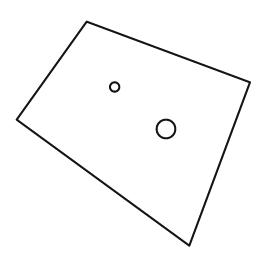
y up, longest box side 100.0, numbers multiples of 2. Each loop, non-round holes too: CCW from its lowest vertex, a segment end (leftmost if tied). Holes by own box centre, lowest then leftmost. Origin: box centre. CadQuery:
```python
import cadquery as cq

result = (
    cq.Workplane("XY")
    .moveTo(24.0, -48.0)
    .lineTo(50.0, 22.0)
    .lineTo(-20.0, 48.0)
    .lineTo(-50.0, 6.0)
    .close()
    .moveTo(14.0, 2.0)
    .circle(4.0)
    .moveTo(-8.0, 20.0)
    .circle(2.0)
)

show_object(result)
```